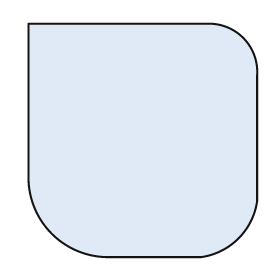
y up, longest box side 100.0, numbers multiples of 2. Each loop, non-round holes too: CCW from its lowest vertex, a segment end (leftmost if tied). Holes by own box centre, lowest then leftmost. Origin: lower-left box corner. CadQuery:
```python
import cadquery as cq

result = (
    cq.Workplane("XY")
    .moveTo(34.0, 0.0)
    .lineTo(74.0, 0.0)
    .threePointArc((90.0, 8.0), (98.0, 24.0))
    .lineTo(98.0, 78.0)
    .threePointArc((92.0, 94.0), (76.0, 100.0))
    .lineTo(0.0, 100.0)
    .lineTo(0.0, 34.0)
    .threePointArc((10.0, 10.0), (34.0, 0.0))
    .close()
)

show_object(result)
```